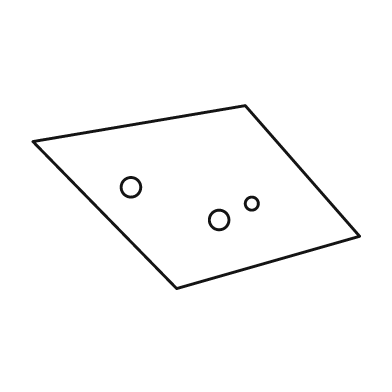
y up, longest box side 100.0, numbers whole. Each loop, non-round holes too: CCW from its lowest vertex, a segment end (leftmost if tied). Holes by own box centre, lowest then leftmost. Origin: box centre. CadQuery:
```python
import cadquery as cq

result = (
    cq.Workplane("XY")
    .moveTo(-6.0, -28.0)
    .lineTo(50.0, -12.0)
    .lineTo(15.0, 28.0)
    .lineTo(-50.0, 17.0)
    .close()
    .moveTo(7.0, -7.0)
    .circle(3.0)
    .moveTo(17.0, -2.0)
    .circle(2.0)
    .moveTo(-20.0, 3.0)
    .circle(3.0)
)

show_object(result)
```